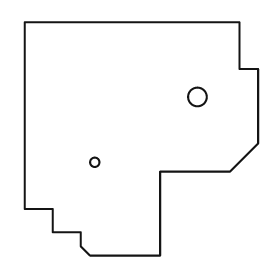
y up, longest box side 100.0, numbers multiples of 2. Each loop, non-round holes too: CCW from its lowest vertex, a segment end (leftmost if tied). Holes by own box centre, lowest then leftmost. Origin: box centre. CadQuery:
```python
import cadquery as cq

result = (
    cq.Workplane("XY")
    .moveTo(-22.0, -50.0)
    .lineTo(8.0, -50.0)
    .lineTo(8.0, -14.0)
    .lineTo(38.0, -14.0)
    .lineTo(50.0, -2.0)
    .lineTo(50.0, 30.0)
    .lineTo(42.0, 30.0)
    .lineTo(42.0, 50.0)
    .lineTo(-50.0, 50.0)
    .lineTo(-50.0, -30.0)
    .lineTo(-38.0, -30.0)
    .lineTo(-38.0, -40.0)
    .lineTo(-26.0, -40.0)
    .lineTo(-26.0, -46.0)
    .close()
    .moveTo(-20.0, -10.0)
    .circle(2.0)
    .moveTo(24.0, 18.0)
    .circle(4.0)
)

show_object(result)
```